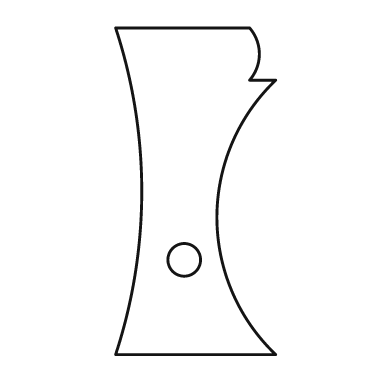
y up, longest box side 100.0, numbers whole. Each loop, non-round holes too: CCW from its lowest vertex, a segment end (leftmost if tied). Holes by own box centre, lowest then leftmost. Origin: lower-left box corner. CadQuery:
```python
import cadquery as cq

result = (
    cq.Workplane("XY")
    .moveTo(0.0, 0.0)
    .lineTo(49.0, 0.0)
    .threePointArc((31.0, 42.0), (49.0, 84.0))
    .lineTo(41.0, 84.0)
    .threePointArc((44.0, 92.0), (41.0, 100.0))
    .lineTo(0.0, 100.0)
    .threePointArc((8.0, 50.0), (0.0, 0.0))
    .close()
    .moveTo(21.0, 29.0)
    .circle(5.0)
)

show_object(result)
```